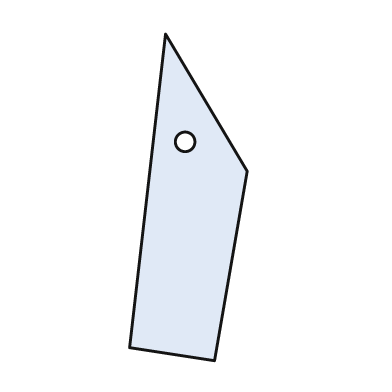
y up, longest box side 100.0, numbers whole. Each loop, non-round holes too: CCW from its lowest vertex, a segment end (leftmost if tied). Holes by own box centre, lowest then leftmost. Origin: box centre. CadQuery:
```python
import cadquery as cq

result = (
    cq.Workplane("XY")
    .moveTo(8.0, -50.0)
    .lineTo(18.0, 8.0)
    .lineTo(-7.0, 50.0)
    .lineTo(-18.0, -46.0)
    .close()
    .moveTo(-1.0, 17.0)
    .circle(3.0)
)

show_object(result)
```